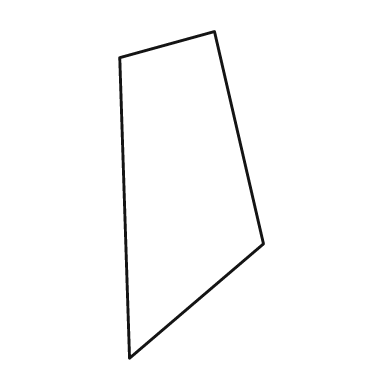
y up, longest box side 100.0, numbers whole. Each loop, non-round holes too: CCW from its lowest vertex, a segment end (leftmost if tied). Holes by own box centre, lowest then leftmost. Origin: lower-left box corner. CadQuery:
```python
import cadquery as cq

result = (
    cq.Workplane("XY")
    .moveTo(3.0, 0.0)
    .lineTo(44.0, 35.0)
    .lineTo(29.0, 100.0)
    .lineTo(0.0, 92.0)
    .close()
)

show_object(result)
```